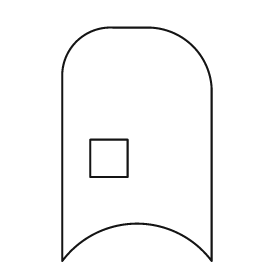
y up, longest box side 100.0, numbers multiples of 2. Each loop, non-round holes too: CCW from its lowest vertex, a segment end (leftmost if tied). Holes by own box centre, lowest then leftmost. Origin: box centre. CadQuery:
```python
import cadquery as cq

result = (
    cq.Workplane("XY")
    .moveTo(-32.0, -50.0)
    .threePointArc((0.0, -34.0), (32.0, -50.0))
    .lineTo(32.0, 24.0)
    .threePointArc((24.0, 42.0), (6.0, 50.0))
    .lineTo(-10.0, 50.0)
    .threePointArc((-26.0, 44.0), (-32.0, 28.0))
    .close()
    .moveTo(-20.0, -14.0)
    .lineTo(-4.0, -14.0)
    .lineTo(-4.0, 2.0)
    .lineTo(-20.0, 2.0)
    .close()
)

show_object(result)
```